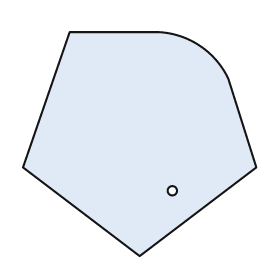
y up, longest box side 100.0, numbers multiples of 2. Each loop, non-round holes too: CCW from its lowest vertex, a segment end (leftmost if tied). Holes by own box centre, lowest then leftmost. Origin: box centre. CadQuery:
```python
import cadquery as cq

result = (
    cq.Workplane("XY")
    .moveTo(0.0, -48.0)
    .lineTo(50.0, -10.0)
    .lineTo(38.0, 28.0)
    .threePointArc((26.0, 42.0), (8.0, 48.0))
    .lineTo(-30.0, 48.0)
    .lineTo(-50.0, -10.0)
    .close()
    .moveTo(14.0, -20.0)
    .circle(2.0)
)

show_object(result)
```